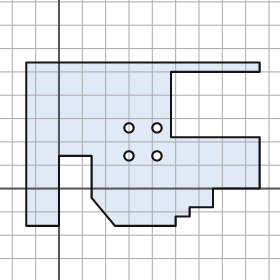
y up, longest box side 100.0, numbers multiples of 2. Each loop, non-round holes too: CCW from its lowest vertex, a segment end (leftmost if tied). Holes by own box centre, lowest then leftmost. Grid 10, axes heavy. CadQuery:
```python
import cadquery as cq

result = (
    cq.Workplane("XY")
    .moveTo(-14.0, -16.0)
    .lineTo(0.0, -16.0)
    .lineTo(0.0, 14.0)
    .lineTo(14.0, 14.0)
    .lineTo(14.0, -4.0)
    .lineTo(24.0, -16.0)
    .lineTo(50.0, -16.0)
    .lineTo(50.0, -12.0)
    .lineTo(56.0, -12.0)
    .lineTo(56.0, -8.0)
    .lineTo(66.0, -8.0)
    .lineTo(66.0, 0.0)
    .lineTo(86.0, 0.0)
    .lineTo(86.0, 22.0)
    .lineTo(48.0, 22.0)
    .lineTo(48.0, 50.0)
    .lineTo(86.0, 50.0)
    .lineTo(86.0, 54.0)
    .lineTo(-14.0, 54.0)
    .close()
    .moveTo(30.0, 14.0)
    .circle(2.0)
    .moveTo(42.0, 14.0)
    .circle(2.0)
    .moveTo(30.0, 26.0)
    .circle(2.0)
    .moveTo(42.0, 26.0)
    .circle(2.0)
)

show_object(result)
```